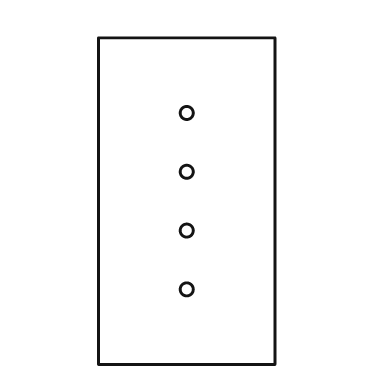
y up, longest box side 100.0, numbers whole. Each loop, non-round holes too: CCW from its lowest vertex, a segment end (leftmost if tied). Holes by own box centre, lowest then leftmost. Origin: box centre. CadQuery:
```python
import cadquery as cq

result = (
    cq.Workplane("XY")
    .moveTo(-27.0, -50.0)
    .lineTo(27.0, -50.0)
    .lineTo(27.0, 50.0)
    .lineTo(-27.0, 50.0)
    .close()
    .moveTo(0.0, -27.0)
    .circle(2.0)
    .moveTo(0.0, -9.0)
    .circle(2.0)
    .moveTo(0.0, 9.0)
    .circle(2.0)
    .moveTo(0.0, 27.0)
    .circle(2.0)
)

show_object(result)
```